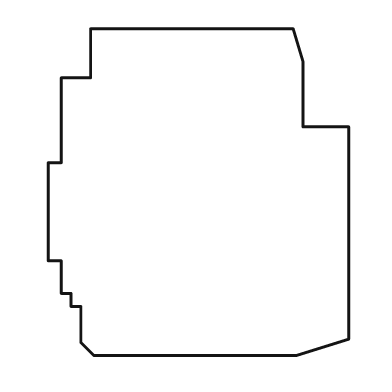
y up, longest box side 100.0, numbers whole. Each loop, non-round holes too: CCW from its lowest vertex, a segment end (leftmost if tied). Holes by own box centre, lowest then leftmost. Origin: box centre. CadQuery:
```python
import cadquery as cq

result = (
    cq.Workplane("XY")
    .moveTo(-32.0, -50.0)
    .lineTo(30.0, -50.0)
    .lineTo(46.0, -45.0)
    .lineTo(46.0, 20.0)
    .lineTo(32.0, 20.0)
    .lineTo(32.0, 40.0)
    .lineTo(29.0, 50.0)
    .lineTo(-33.0, 50.0)
    .lineTo(-33.0, 35.0)
    .lineTo(-42.0, 35.0)
    .lineTo(-42.0, 9.0)
    .lineTo(-46.0, 9.0)
    .lineTo(-46.0, -21.0)
    .lineTo(-42.0, -21.0)
    .lineTo(-42.0, -31.0)
    .lineTo(-39.0, -31.0)
    .lineTo(-39.0, -35.0)
    .lineTo(-36.0, -35.0)
    .lineTo(-36.0, -46.0)
    .close()
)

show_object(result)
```